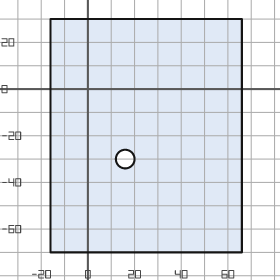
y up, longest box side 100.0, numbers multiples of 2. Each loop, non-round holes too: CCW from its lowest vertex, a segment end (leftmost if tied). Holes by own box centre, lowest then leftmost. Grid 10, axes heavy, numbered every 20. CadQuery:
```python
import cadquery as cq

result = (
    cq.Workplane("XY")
    .moveTo(-16.0, -70.0)
    .lineTo(66.0, -70.0)
    .lineTo(66.0, 30.0)
    .lineTo(-16.0, 30.0)
    .close()
    .moveTo(16.0, -30.0)
    .circle(4.0)
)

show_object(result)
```